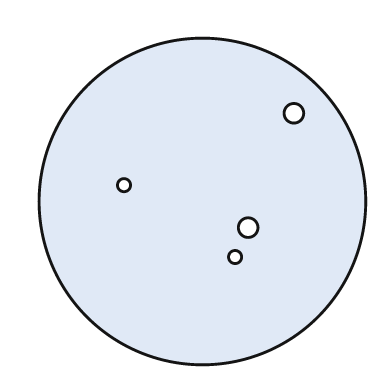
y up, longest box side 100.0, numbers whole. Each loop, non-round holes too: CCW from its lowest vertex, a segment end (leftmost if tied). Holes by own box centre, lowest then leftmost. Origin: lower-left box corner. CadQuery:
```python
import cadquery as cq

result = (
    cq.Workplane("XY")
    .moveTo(50.0, 50.0)
    .circle(50.0)
    .moveTo(60.0, 33.0)
    .circle(2.0)
    .moveTo(64.0, 42.0)
    .circle(3.0)
    .moveTo(26.0, 55.0)
    .circle(2.0)
    .moveTo(78.0, 77.0)
    .circle(3.0)
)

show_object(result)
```